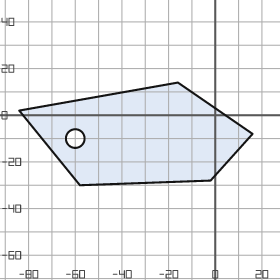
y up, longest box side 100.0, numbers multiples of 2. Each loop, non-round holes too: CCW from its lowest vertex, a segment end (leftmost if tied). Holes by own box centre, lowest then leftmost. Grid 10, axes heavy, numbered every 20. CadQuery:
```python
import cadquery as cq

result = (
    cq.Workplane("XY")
    .moveTo(-58.0, -30.0)
    .lineTo(-2.0, -28.0)
    .lineTo(16.0, -8.0)
    .lineTo(-16.0, 14.0)
    .lineTo(-84.0, 2.0)
    .close()
    .moveTo(-60.0, -10.0)
    .circle(4.0)
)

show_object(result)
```